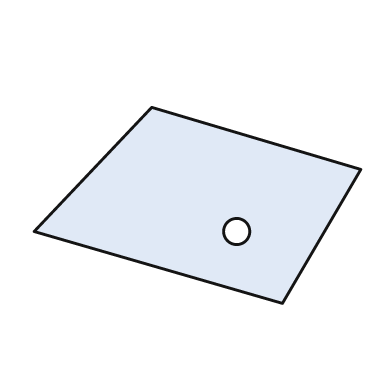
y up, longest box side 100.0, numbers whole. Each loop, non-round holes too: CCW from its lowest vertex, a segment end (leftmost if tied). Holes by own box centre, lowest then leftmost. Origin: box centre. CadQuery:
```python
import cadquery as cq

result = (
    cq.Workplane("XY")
    .moveTo(26.0, -30.0)
    .lineTo(50.0, 11.0)
    .lineTo(-14.0, 30.0)
    .lineTo(-50.0, -8.0)
    .close()
    .moveTo(12.0, -8.0)
    .circle(4.0)
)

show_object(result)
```